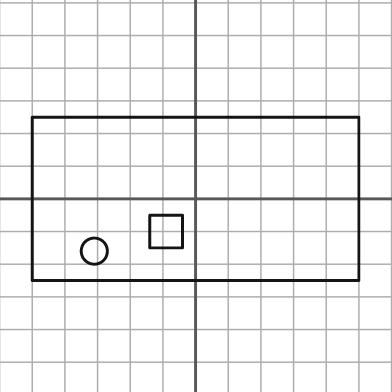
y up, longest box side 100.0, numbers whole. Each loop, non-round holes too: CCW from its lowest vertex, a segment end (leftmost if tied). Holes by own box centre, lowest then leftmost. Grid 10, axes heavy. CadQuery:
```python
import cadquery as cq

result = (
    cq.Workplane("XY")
    .moveTo(-50.0, -25.0)
    .lineTo(50.0, -25.0)
    .lineTo(50.0, 25.0)
    .lineTo(-50.0, 25.0)
    .close()
    .moveTo(-31.0, -16.0)
    .circle(4.0)
    .moveTo(-14.0, -15.0)
    .lineTo(-4.0, -15.0)
    .lineTo(-4.0, -5.0)
    .lineTo(-14.0, -5.0)
    .close()
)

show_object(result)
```